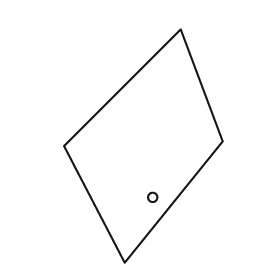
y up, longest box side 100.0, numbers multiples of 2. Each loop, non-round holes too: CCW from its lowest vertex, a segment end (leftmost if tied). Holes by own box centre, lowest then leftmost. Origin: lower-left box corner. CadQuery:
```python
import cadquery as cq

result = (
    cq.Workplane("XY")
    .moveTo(26.0, 0.0)
    .lineTo(68.0, 52.0)
    .lineTo(50.0, 100.0)
    .lineTo(0.0, 50.0)
    .close()
    .moveTo(38.0, 28.0)
    .circle(2.0)
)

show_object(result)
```